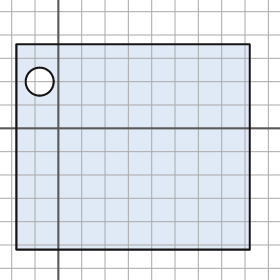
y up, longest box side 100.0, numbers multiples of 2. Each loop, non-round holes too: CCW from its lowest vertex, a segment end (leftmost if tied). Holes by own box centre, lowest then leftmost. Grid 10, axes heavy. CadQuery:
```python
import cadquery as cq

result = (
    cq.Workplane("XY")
    .moveTo(-18.0, -52.0)
    .lineTo(82.0, -52.0)
    .lineTo(82.0, 36.0)
    .lineTo(-18.0, 36.0)
    .close()
    .moveTo(-8.0, 20.0)
    .circle(6.0)
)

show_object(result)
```